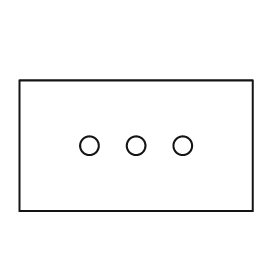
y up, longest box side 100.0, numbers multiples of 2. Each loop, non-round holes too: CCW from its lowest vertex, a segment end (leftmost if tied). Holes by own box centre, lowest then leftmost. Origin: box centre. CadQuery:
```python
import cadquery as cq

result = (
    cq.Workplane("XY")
    .moveTo(-50.0, -28.0)
    .lineTo(50.0, -28.0)
    .lineTo(50.0, 28.0)
    .lineTo(-50.0, 28.0)
    .close()
    .moveTo(-20.0, 0.0)
    .circle(4.0)
    .moveTo(0.0, 0.0)
    .circle(4.0)
    .moveTo(20.0, 0.0)
    .circle(4.0)
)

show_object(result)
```